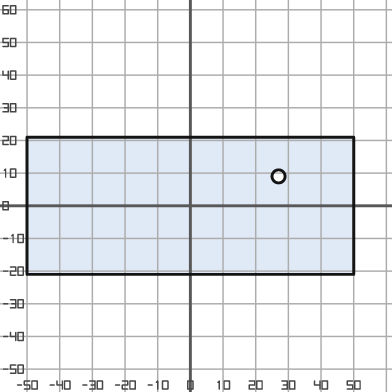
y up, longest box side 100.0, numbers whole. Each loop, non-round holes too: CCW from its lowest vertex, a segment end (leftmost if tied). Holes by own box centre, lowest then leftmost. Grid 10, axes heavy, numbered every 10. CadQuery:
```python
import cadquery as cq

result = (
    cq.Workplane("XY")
    .moveTo(-50.0, -21.0)
    .lineTo(50.0, -21.0)
    .lineTo(50.0, 21.0)
    .lineTo(-50.0, 21.0)
    .close()
    .moveTo(27.0, 9.0)
    .circle(2.0)
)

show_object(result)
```